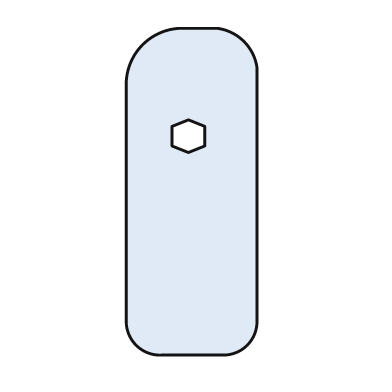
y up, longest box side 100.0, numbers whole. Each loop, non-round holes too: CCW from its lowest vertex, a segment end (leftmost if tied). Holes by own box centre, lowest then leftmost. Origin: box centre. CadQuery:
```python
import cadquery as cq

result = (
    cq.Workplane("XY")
    .moveTo(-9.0, -50.0)
    .lineTo(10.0, -50.0)
    .threePointArc((17.0, -47.0), (20.0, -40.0))
    .lineTo(20.0, 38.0)
    .threePointArc((16.0, 46.0), (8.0, 50.0))
    .lineTo(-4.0, 50.0)
    .threePointArc((-15.0, 45.0), (-20.0, 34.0))
    .lineTo(-20.0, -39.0)
    .threePointArc((-17.0, -47.0), (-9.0, -50.0))
    .close()
    .moveTo(-1.0, 12.0)
    .lineTo(4.0, 14.0)
    .lineTo(4.0, 20.0)
    .lineTo(-1.0, 22.0)
    .lineTo(-6.0, 20.0)
    .lineTo(-6.0, 14.0)
    .close()
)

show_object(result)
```